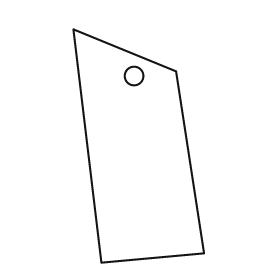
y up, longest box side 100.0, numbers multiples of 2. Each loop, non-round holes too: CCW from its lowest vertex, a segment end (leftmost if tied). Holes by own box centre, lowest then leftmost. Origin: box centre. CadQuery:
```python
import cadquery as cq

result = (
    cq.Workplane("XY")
    .moveTo(-16.0, -50.0)
    .lineTo(28.0, -46.0)
    .lineTo(16.0, 32.0)
    .lineTo(-28.0, 50.0)
    .close()
    .moveTo(-2.0, 30.0)
    .circle(4.0)
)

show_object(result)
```